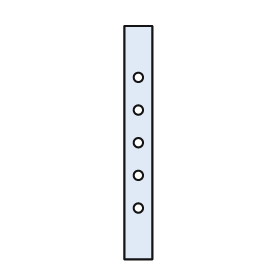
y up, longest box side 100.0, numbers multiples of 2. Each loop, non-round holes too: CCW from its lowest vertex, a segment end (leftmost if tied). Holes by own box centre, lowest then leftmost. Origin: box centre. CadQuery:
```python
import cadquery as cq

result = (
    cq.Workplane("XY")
    .moveTo(-6.0, -50.0)
    .lineTo(6.0, -50.0)
    .lineTo(6.0, 50.0)
    .lineTo(-6.0, 50.0)
    .close()
    .moveTo(0.0, -28.0)
    .circle(2.0)
    .moveTo(0.0, -14.0)
    .circle(2.0)
    .moveTo(0.0, 0.0)
    .circle(2.0)
    .moveTo(0.0, 14.0)
    .circle(2.0)
    .moveTo(0.0, 28.0)
    .circle(2.0)
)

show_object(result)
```